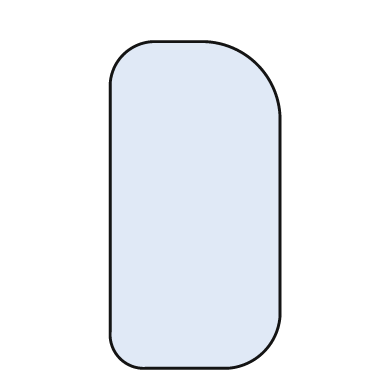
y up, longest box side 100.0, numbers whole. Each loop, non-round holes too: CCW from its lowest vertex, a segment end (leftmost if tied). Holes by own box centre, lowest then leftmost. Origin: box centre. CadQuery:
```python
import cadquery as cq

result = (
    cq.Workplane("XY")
    .moveTo(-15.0, -50.0)
    .lineTo(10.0, -50.0)
    .threePointArc((21.0, -45.0), (26.0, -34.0))
    .lineTo(26.0, 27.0)
    .threePointArc((19.0, 43.0), (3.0, 50.0))
    .lineTo(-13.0, 50.0)
    .threePointArc((-22.0, 46.0), (-26.0, 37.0))
    .lineTo(-26.0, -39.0)
    .threePointArc((-23.0, -47.0), (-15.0, -50.0))
    .close()
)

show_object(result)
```